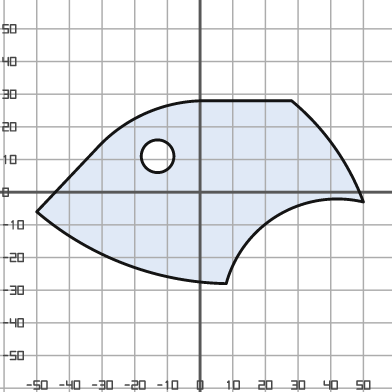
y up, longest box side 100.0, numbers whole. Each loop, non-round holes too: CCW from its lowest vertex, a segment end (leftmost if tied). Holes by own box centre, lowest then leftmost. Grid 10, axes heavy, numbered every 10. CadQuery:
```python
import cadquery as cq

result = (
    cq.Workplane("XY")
    .moveTo(8.0, -28.0)
    .threePointArc((24.0, -7.0), (50.0, -3.0))
    .threePointArc((41.0, 14.0), (28.0, 28.0))
    .lineTo(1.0, 28.0)
    .threePointArc((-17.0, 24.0), (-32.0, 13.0))
    .lineTo(-50.0, -6.0)
    .threePointArc((-23.0, -22.0), (8.0, -28.0))
    .close()
    .moveTo(-13.0, 11.0)
    .circle(5.0)
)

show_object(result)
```